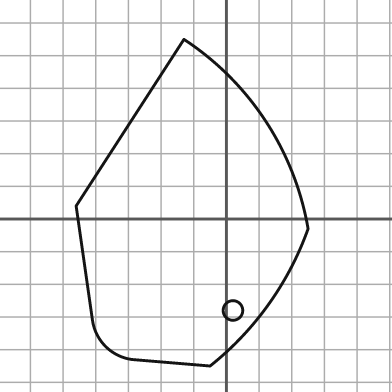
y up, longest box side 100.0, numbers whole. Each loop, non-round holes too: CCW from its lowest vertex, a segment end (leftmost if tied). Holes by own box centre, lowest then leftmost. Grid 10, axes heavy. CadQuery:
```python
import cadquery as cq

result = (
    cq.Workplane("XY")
    .moveTo(-5.0, -45.0)
    .threePointArc((13.0, -26.0), (25.0, -3.0))
    .threePointArc((12.0, 30.0), (-13.0, 55.0))
    .lineTo(-46.0, 4.0)
    .lineTo(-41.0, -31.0)
    .threePointArc((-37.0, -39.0), (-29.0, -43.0))
    .close()
    .moveTo(2.0, -28.0)
    .circle(3.0)
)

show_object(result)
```